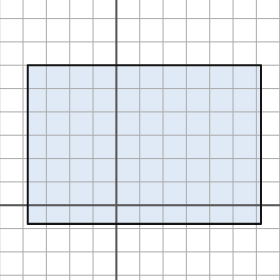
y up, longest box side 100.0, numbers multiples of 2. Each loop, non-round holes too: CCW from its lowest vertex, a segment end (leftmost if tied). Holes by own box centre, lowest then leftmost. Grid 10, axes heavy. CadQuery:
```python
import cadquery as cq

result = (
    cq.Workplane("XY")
    .moveTo(-38.0, -8.0)
    .lineTo(62.0, -8.0)
    .lineTo(62.0, 60.0)
    .lineTo(-38.0, 60.0)
    .close()
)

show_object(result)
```